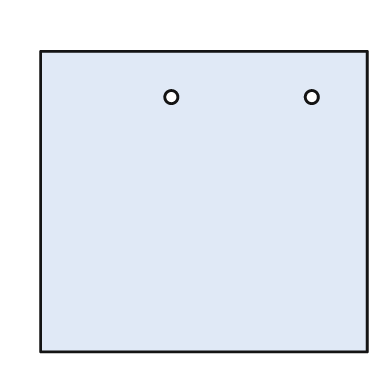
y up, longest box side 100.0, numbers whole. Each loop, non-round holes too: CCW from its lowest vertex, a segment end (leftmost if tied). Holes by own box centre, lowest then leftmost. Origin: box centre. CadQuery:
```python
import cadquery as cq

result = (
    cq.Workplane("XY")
    .moveTo(-50.0, -46.0)
    .lineTo(50.0, -46.0)
    .lineTo(50.0, 46.0)
    .lineTo(-50.0, 46.0)
    .close()
    .moveTo(-10.0, 32.0)
    .circle(2.0)
    .moveTo(33.0, 32.0)
    .circle(2.0)
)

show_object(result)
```